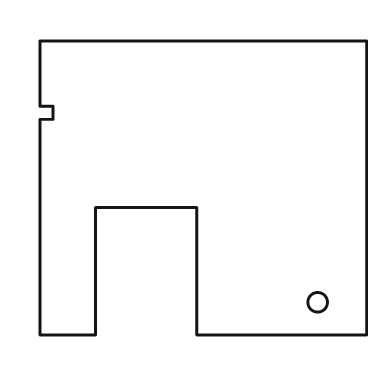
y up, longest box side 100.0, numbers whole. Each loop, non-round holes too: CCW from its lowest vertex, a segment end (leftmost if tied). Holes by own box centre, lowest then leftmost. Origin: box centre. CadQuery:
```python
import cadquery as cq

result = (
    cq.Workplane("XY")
    .moveTo(-50.0, -45.0)
    .lineTo(-33.0, -45.0)
    .lineTo(-33.0, -6.0)
    .lineTo(-2.0, -6.0)
    .lineTo(-2.0, -45.0)
    .lineTo(50.0, -45.0)
    .lineTo(50.0, 45.0)
    .lineTo(-50.0, 45.0)
    .lineTo(-50.0, 25.0)
    .lineTo(-46.0, 25.0)
    .lineTo(-46.0, 21.0)
    .lineTo(-50.0, 21.0)
    .close()
    .moveTo(35.0, -35.0)
    .circle(3.0)
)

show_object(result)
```